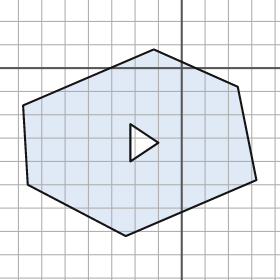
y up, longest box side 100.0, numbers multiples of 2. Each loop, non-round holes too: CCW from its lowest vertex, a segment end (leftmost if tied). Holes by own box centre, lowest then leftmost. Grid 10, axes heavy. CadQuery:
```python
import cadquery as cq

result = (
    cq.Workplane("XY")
    .moveTo(-24.0, -72.0)
    .lineTo(32.0, -48.0)
    .lineTo(24.0, -8.0)
    .lineTo(-12.0, 8.0)
    .lineTo(-68.0, -16.0)
    .lineTo(-66.0, -50.0)
    .close()
    .moveTo(-22.0, -40.0)
    .lineTo(-10.0, -32.0)
    .lineTo(-22.0, -24.0)
    .close()
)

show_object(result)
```